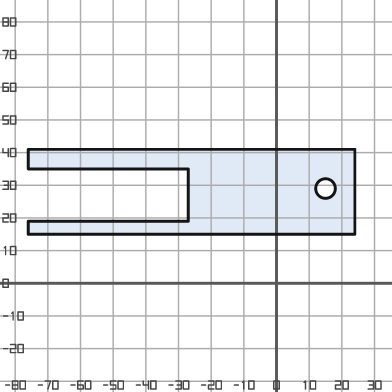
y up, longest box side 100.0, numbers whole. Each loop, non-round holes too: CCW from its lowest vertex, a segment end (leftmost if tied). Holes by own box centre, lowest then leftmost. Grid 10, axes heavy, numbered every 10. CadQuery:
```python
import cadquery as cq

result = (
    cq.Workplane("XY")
    .moveTo(-76.0, 15.0)
    .lineTo(24.0, 15.0)
    .lineTo(24.0, 41.0)
    .lineTo(-76.0, 41.0)
    .lineTo(-76.0, 35.0)
    .lineTo(-27.0, 35.0)
    .lineTo(-27.0, 19.0)
    .lineTo(-76.0, 19.0)
    .close()
    .moveTo(15.0, 29.0)
    .circle(3.0)
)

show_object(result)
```